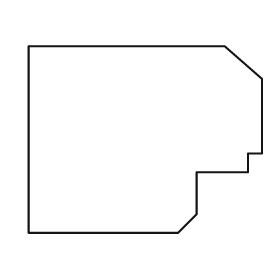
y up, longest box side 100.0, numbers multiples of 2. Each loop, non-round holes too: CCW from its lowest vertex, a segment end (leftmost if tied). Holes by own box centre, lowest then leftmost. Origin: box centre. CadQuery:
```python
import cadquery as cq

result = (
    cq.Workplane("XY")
    .moveTo(-50.0, -40.0)
    .lineTo(14.0, -40.0)
    .lineTo(22.0, -32.0)
    .lineTo(22.0, -14.0)
    .lineTo(44.0, -14.0)
    .lineTo(44.0, -6.0)
    .lineTo(50.0, -6.0)
    .lineTo(50.0, 26.0)
    .lineTo(34.0, 40.0)
    .lineTo(-50.0, 40.0)
    .close()
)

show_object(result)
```